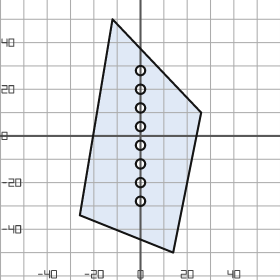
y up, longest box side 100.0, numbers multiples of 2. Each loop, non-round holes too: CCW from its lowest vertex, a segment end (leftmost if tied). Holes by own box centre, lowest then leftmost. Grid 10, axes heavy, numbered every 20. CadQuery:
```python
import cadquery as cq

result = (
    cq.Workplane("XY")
    .moveTo(14.0, -50.0)
    .lineTo(26.0, 10.0)
    .lineTo(-12.0, 50.0)
    .lineTo(-26.0, -34.0)
    .close()
    .moveTo(0.0, -28.0)
    .circle(2.0)
    .moveTo(0.0, -20.0)
    .circle(2.0)
    .moveTo(0.0, -12.0)
    .circle(2.0)
    .moveTo(0.0, -4.0)
    .circle(2.0)
    .moveTo(0.0, 4.0)
    .circle(2.0)
    .moveTo(0.0, 12.0)
    .circle(2.0)
    .moveTo(0.0, 20.0)
    .circle(2.0)
    .moveTo(0.0, 28.0)
    .circle(2.0)
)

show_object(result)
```